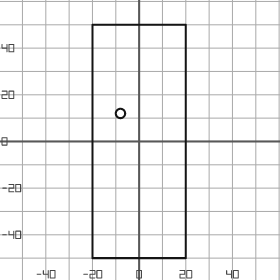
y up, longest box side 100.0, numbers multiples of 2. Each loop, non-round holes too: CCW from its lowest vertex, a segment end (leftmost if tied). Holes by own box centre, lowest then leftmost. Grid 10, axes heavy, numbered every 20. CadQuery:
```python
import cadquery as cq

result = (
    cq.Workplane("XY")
    .moveTo(-20.0, -50.0)
    .lineTo(20.0, -50.0)
    .lineTo(20.0, 50.0)
    .lineTo(-20.0, 50.0)
    .close()
    .moveTo(-8.0, 12.0)
    .circle(2.0)
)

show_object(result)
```